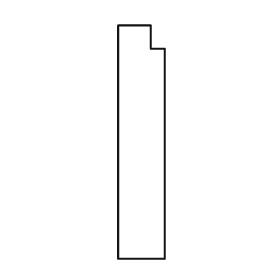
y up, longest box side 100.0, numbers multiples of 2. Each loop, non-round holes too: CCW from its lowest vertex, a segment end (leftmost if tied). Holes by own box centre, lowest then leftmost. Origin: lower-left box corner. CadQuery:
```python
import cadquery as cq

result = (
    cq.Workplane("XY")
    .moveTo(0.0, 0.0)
    .lineTo(20.0, 0.0)
    .lineTo(20.0, 90.0)
    .lineTo(14.0, 90.0)
    .lineTo(14.0, 100.0)
    .lineTo(0.0, 100.0)
    .close()
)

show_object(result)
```